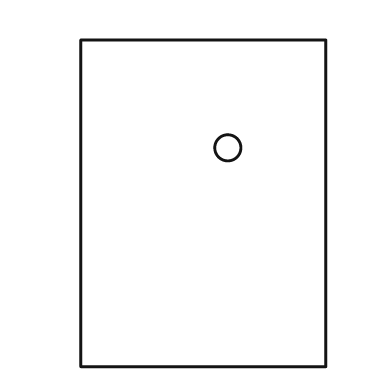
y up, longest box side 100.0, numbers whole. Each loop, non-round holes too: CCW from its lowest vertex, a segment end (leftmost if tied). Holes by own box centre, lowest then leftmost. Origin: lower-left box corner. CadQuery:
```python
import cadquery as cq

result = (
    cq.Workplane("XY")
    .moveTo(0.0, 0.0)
    .lineTo(75.0, 0.0)
    .lineTo(75.0, 100.0)
    .lineTo(0.0, 100.0)
    .close()
    .moveTo(45.0, 67.0)
    .circle(4.0)
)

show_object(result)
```